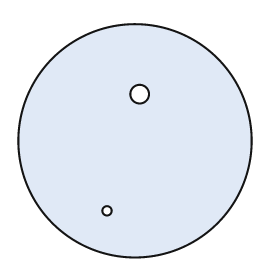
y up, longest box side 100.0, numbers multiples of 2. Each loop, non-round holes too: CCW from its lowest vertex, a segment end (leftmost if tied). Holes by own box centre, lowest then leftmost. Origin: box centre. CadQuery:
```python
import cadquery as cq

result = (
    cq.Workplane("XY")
    .moveTo(0.0, 0.0)
    .circle(50.0)
    .moveTo(-12.0, -30.0)
    .circle(2.0)
    .moveTo(2.0, 20.0)
    .circle(4.0)
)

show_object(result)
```